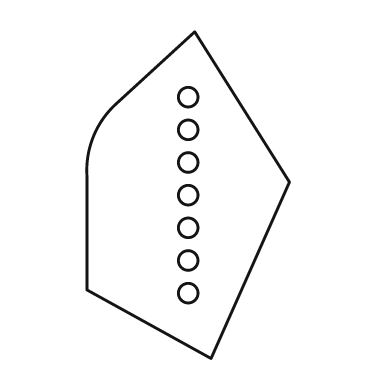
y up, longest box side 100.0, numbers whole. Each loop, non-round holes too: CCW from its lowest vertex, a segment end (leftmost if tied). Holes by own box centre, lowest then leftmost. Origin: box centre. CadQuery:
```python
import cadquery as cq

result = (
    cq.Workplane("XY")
    .moveTo(7.0, -50.0)
    .lineTo(31.0, 4.0)
    .lineTo(2.0, 50.0)
    .lineTo(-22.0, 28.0)
    .threePointArc((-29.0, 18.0), (-31.0, 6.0))
    .lineTo(-31.0, -29.0)
    .close()
    .moveTo(0.0, -30.0)
    .circle(3.0)
    .moveTo(0.0, -20.0)
    .circle(3.0)
    .moveTo(0.0, -10.0)
    .circle(3.0)
    .moveTo(0.0, 0.0)
    .circle(3.0)
    .moveTo(0.0, 10.0)
    .circle(3.0)
    .moveTo(0.0, 20.0)
    .circle(3.0)
    .moveTo(0.0, 30.0)
    .circle(3.0)
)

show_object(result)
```